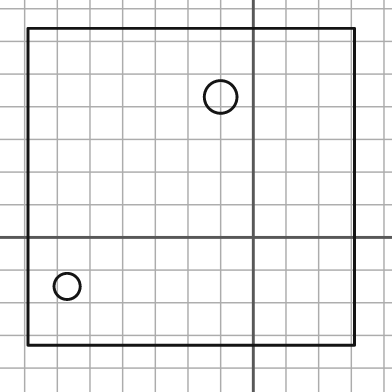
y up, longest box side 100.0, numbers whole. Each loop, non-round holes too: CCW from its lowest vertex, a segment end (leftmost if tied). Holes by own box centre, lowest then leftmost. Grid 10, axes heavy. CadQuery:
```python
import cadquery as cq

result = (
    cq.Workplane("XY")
    .moveTo(-69.0, -33.0)
    .lineTo(31.0, -33.0)
    .lineTo(31.0, 64.0)
    .lineTo(-69.0, 64.0)
    .close()
    .moveTo(-57.0, -15.0)
    .circle(4.0)
    .moveTo(-10.0, 43.0)
    .circle(5.0)
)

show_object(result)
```